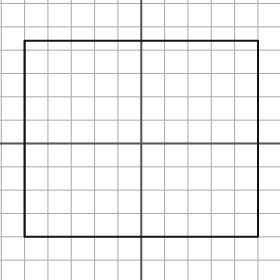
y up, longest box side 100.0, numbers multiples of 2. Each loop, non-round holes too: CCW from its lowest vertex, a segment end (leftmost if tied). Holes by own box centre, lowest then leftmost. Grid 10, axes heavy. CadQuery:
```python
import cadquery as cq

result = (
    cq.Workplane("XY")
    .moveTo(-50.0, -40.0)
    .lineTo(50.0, -40.0)
    .lineTo(50.0, 44.0)
    .lineTo(-50.0, 44.0)
    .close()
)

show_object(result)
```